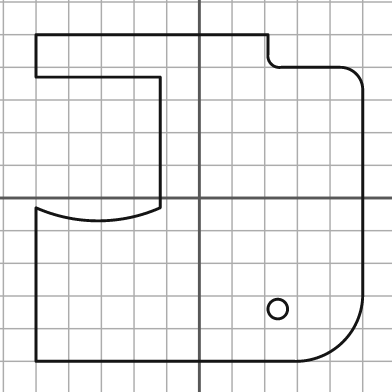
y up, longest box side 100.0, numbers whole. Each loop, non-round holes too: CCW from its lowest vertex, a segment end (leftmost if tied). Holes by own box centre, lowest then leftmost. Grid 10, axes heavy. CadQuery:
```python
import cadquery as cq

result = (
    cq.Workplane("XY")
    .moveTo(-50.0, -50.0)
    .lineTo(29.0, -50.0)
    .threePointArc((44.0, -44.0), (50.0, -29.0))
    .lineTo(50.0, 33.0)
    .threePointArc((48.0, 38.0), (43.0, 40.0))
    .lineTo(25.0, 40.0)
    .threePointArc((22.0, 41.0), (21.0, 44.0))
    .lineTo(21.0, 50.0)
    .lineTo(-50.0, 50.0)
    .lineTo(-50.0, 37.0)
    .lineTo(-12.0, 37.0)
    .lineTo(-12.0, -3.0)
    .threePointArc((-31.0, -7.0), (-50.0, -3.0))
    .close()
    .moveTo(24.0, -34.0)
    .circle(3.0)
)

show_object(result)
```